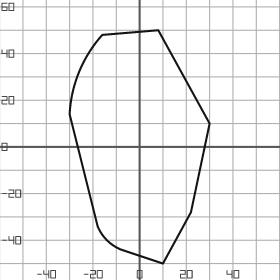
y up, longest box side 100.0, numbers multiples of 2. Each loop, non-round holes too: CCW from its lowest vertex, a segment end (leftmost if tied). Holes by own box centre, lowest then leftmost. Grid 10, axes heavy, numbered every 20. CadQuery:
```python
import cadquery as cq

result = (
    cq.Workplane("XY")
    .moveTo(10.0, -50.0)
    .lineTo(22.0, -28.0)
    .lineTo(30.0, 10.0)
    .lineTo(8.0, 50.0)
    .lineTo(-16.0, 48.0)
    .threePointArc((-26.0, 32.0), (-30.0, 14.0))
    .lineTo(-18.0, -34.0)
    .threePointArc((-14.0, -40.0), (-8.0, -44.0))
    .close()
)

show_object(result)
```